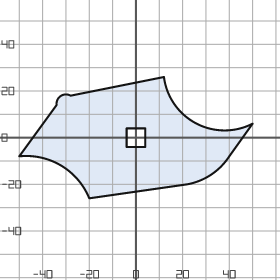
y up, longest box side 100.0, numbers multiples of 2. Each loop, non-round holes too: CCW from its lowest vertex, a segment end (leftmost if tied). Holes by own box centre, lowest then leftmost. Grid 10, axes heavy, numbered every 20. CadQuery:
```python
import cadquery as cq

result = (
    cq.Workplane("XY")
    .moveTo(-20.0, -26.0)
    .lineTo(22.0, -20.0)
    .threePointArc((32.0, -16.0), (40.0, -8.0))
    .lineTo(50.0, 6.0)
    .threePointArc((26.0, 6.0), (12.0, 26.0))
    .lineTo(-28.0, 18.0)
    .threePointArc((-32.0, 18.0), (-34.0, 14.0))
    .lineTo(-50.0, -8.0)
    .threePointArc((-32.0, -12.0), (-20.0, -26.0))
    .close()
    .moveTo(-4.0, -4.0)
    .lineTo(4.0, -4.0)
    .lineTo(4.0, 4.0)
    .lineTo(-4.0, 4.0)
    .close()
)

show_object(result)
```